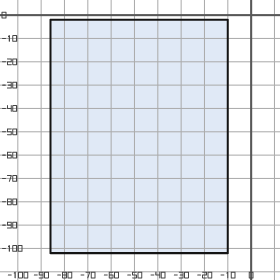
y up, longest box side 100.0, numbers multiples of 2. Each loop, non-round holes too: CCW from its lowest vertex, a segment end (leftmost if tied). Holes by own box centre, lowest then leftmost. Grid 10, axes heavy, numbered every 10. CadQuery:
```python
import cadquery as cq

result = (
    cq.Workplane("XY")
    .moveTo(-86.0, -102.0)
    .lineTo(-10.0, -102.0)
    .lineTo(-10.0, -2.0)
    .lineTo(-86.0, -2.0)
    .close()
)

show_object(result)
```